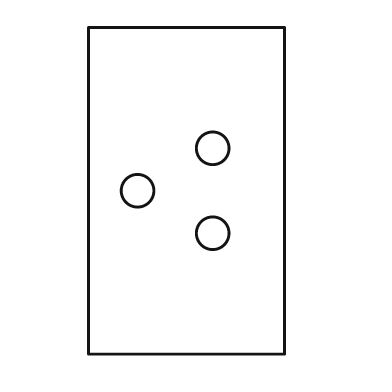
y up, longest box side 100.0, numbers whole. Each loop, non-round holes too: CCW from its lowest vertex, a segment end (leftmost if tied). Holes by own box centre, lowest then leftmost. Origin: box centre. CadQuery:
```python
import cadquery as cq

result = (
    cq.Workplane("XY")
    .moveTo(-30.0, -50.0)
    .lineTo(30.0, -50.0)
    .lineTo(30.0, 50.0)
    .lineTo(-30.0, 50.0)
    .close()
    .moveTo(8.0, -13.0)
    .circle(5.0)
    .moveTo(-15.0, 0.0)
    .circle(5.0)
    .moveTo(8.0, 13.0)
    .circle(5.0)
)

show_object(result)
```